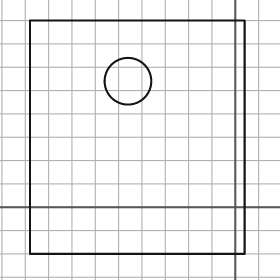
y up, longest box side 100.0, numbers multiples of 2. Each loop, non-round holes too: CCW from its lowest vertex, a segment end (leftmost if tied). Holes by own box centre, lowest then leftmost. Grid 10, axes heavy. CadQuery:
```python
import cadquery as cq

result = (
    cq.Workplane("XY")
    .moveTo(-88.0, -20.0)
    .lineTo(4.0, -20.0)
    .lineTo(4.0, 80.0)
    .lineTo(-88.0, 80.0)
    .close()
    .moveTo(-46.0, 54.0)
    .circle(10.0)
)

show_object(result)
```